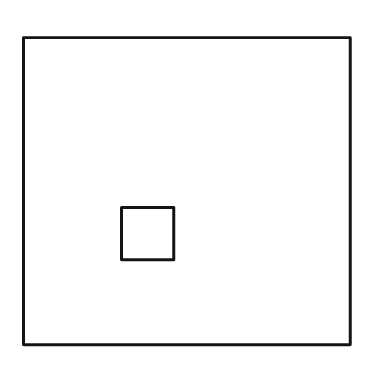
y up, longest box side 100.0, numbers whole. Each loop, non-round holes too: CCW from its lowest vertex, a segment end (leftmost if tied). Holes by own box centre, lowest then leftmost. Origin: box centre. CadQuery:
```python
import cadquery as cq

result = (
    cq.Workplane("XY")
    .moveTo(-50.0, -47.0)
    .lineTo(50.0, -47.0)
    .lineTo(50.0, 47.0)
    .lineTo(-50.0, 47.0)
    .close()
    .moveTo(-20.0, -21.0)
    .lineTo(-4.0, -21.0)
    .lineTo(-4.0, -5.0)
    .lineTo(-20.0, -5.0)
    .close()
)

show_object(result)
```